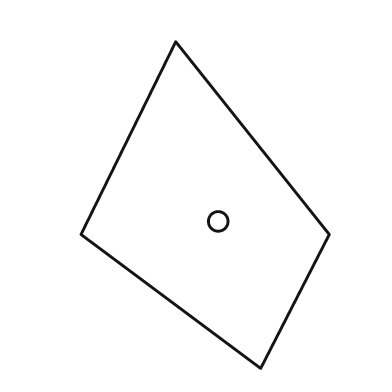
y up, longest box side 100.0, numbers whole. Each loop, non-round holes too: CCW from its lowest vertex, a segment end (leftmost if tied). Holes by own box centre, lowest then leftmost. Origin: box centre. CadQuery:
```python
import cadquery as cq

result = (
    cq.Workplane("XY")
    .moveTo(17.0, -50.0)
    .lineTo(38.0, -9.0)
    .lineTo(-9.0, 50.0)
    .lineTo(-38.0, -9.0)
    .close()
    .moveTo(4.0, -5.0)
    .circle(3.0)
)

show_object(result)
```